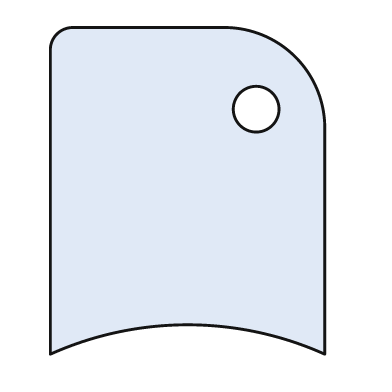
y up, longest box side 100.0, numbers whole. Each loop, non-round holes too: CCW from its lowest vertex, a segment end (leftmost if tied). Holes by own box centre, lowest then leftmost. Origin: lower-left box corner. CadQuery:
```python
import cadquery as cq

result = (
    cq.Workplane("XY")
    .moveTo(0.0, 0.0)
    .threePointArc((42.0, 9.0), (84.0, 0.0))
    .lineTo(84.0, 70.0)
    .threePointArc((75.0, 91.0), (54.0, 100.0))
    .lineTo(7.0, 100.0)
    .threePointArc((2.0, 98.0), (0.0, 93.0))
    .close()
    .moveTo(63.0, 75.0)
    .circle(7.0)
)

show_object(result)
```